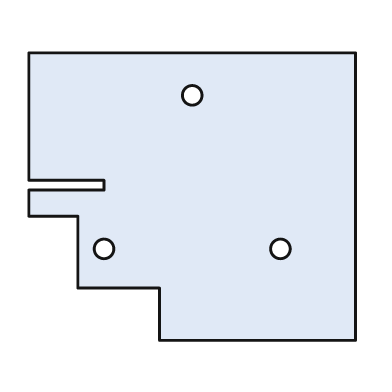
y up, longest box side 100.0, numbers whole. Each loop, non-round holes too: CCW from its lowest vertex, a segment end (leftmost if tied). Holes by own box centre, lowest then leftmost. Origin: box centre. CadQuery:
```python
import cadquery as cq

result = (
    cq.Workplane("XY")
    .moveTo(-10.0, -44.0)
    .lineTo(50.0, -44.0)
    .lineTo(50.0, 44.0)
    .lineTo(-50.0, 44.0)
    .lineTo(-50.0, 5.0)
    .lineTo(-27.0, 5.0)
    .lineTo(-27.0, 2.0)
    .lineTo(-50.0, 2.0)
    .lineTo(-50.0, -6.0)
    .lineTo(-35.0, -6.0)
    .lineTo(-35.0, -28.0)
    .lineTo(-10.0, -28.0)
    .close()
    .moveTo(-27.0, -16.0)
    .circle(3.0)
    .moveTo(27.0, -16.0)
    .circle(3.0)
    .moveTo(0.0, 31.0)
    .circle(3.0)
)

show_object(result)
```